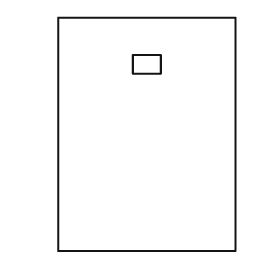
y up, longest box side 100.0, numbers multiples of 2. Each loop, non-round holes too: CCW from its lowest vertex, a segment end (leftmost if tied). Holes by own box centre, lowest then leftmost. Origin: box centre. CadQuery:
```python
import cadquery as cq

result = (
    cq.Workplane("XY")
    .moveTo(-38.0, -50.0)
    .lineTo(38.0, -50.0)
    .lineTo(38.0, 50.0)
    .lineTo(-38.0, 50.0)
    .close()
    .moveTo(-6.0, 26.0)
    .lineTo(6.0, 26.0)
    .lineTo(6.0, 34.0)
    .lineTo(-6.0, 34.0)
    .close()
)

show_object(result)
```